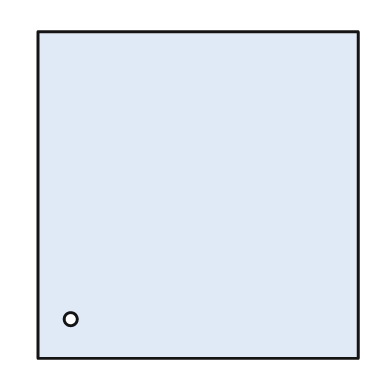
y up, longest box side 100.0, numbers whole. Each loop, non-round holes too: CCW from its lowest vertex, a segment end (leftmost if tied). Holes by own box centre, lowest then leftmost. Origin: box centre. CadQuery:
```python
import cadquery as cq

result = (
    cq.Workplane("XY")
    .moveTo(-49.0, -50.0)
    .lineTo(49.0, -50.0)
    .lineTo(49.0, 50.0)
    .lineTo(-49.0, 50.0)
    .close()
    .moveTo(-39.0, -38.0)
    .circle(2.0)
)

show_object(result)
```